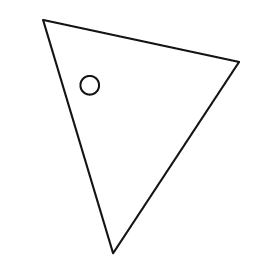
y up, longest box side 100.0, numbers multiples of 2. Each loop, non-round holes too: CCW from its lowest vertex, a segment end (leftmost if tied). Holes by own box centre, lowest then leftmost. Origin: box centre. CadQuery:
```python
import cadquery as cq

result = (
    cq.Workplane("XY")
    .moveTo(-12.0, -50.0)
    .lineTo(42.0, 32.0)
    .lineTo(-42.0, 50.0)
    .close()
    .moveTo(-22.0, 22.0)
    .circle(4.0)
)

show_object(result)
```